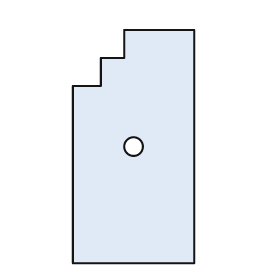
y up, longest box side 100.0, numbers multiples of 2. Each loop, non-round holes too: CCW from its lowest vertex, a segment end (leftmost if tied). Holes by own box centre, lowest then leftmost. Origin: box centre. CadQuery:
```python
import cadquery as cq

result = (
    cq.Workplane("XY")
    .moveTo(-26.0, -50.0)
    .lineTo(26.0, -50.0)
    .lineTo(26.0, 50.0)
    .lineTo(-4.0, 50.0)
    .lineTo(-4.0, 38.0)
    .lineTo(-14.0, 38.0)
    .lineTo(-14.0, 26.0)
    .lineTo(-26.0, 26.0)
    .close()
    .moveTo(0.0, 0.0)
    .circle(4.0)
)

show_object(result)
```